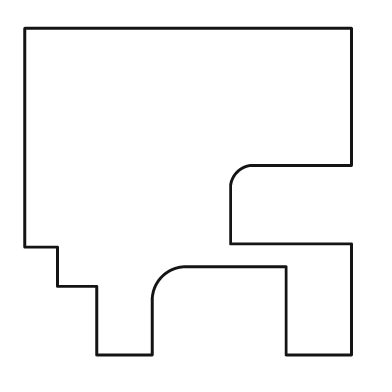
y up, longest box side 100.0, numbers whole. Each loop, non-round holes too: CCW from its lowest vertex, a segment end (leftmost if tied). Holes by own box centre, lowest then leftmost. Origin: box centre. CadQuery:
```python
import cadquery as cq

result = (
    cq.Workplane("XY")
    .moveTo(-28.0, -50.0)
    .lineTo(-11.0, -50.0)
    .lineTo(-11.0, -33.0)
    .threePointArc((-8.0, -26.0), (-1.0, -23.0))
    .lineTo(30.0, -23.0)
    .lineTo(30.0, -50.0)
    .lineTo(50.0, -50.0)
    .lineTo(50.0, -16.0)
    .lineTo(13.0, -16.0)
    .lineTo(13.0, 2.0)
    .threePointArc((15.0, 6.0), (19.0, 8.0))
    .lineTo(50.0, 8.0)
    .lineTo(50.0, 50.0)
    .lineTo(-50.0, 50.0)
    .lineTo(-50.0, -17.0)
    .lineTo(-40.0, -17.0)
    .lineTo(-40.0, -29.0)
    .lineTo(-28.0, -29.0)
    .close()
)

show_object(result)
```